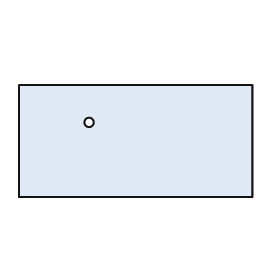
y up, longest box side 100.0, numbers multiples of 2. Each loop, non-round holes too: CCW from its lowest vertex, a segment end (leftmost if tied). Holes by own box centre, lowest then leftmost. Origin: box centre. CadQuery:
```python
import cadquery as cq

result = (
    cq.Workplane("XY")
    .moveTo(-50.0, -24.0)
    .lineTo(50.0, -24.0)
    .lineTo(50.0, 24.0)
    .lineTo(-50.0, 24.0)
    .close()
    .moveTo(-20.0, 8.0)
    .circle(2.0)
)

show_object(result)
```